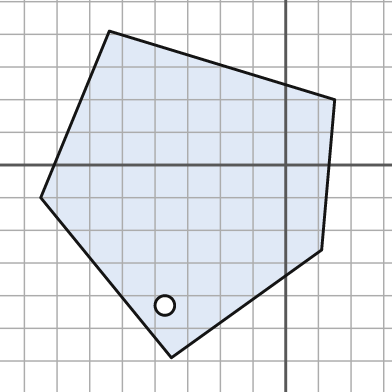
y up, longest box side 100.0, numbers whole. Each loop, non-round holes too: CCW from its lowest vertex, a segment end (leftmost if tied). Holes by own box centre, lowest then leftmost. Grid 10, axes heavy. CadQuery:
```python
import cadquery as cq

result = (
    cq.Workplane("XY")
    .moveTo(-35.0, -59.0)
    .lineTo(11.0, -26.0)
    .lineTo(15.0, 20.0)
    .lineTo(-54.0, 41.0)
    .lineTo(-75.0, -10.0)
    .close()
    .moveTo(-37.0, -43.0)
    .circle(3.0)
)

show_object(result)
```